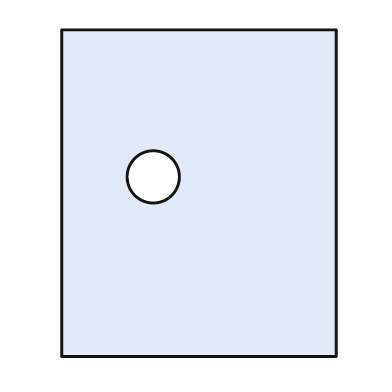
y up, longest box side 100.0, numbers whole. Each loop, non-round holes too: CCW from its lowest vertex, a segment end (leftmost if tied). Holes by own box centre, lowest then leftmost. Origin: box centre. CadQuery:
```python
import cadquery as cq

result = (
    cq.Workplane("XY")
    .moveTo(-42.0, -50.0)
    .lineTo(42.0, -50.0)
    .lineTo(42.0, 50.0)
    .lineTo(-42.0, 50.0)
    .close()
    .moveTo(-14.0, 5.0)
    .circle(8.0)
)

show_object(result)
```